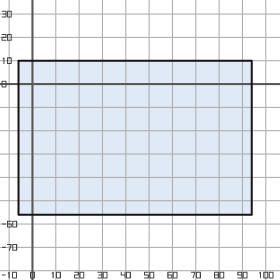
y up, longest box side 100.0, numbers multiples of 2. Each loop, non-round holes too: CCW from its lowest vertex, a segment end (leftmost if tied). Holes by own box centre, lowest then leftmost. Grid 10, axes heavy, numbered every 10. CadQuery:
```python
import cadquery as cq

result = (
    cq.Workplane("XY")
    .moveTo(-6.0, -56.0)
    .lineTo(94.0, -56.0)
    .lineTo(94.0, 10.0)
    .lineTo(-6.0, 10.0)
    .close()
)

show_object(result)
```